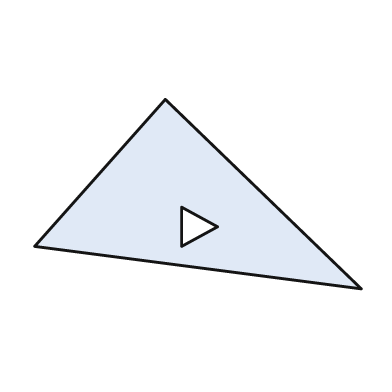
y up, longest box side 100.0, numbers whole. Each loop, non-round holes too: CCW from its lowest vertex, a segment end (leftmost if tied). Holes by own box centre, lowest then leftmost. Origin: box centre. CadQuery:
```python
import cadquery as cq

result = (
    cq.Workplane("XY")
    .moveTo(50.0, -29.0)
    .lineTo(-10.0, 29.0)
    .lineTo(-50.0, -16.0)
    .close()
    .moveTo(-5.0, -16.0)
    .lineTo(6.0, -10.0)
    .lineTo(-5.0, -4.0)
    .close()
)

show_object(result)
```